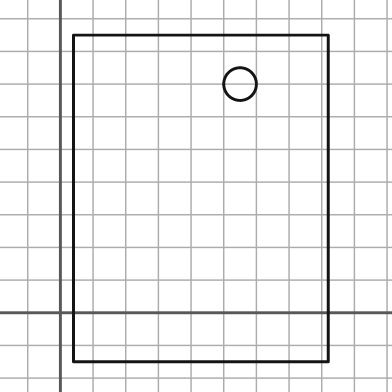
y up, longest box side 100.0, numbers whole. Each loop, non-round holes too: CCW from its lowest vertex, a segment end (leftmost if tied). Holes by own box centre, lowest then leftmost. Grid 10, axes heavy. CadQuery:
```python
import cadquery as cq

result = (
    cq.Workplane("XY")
    .moveTo(4.0, -15.0)
    .lineTo(82.0, -15.0)
    .lineTo(82.0, 85.0)
    .lineTo(4.0, 85.0)
    .close()
    .moveTo(55.0, 70.0)
    .circle(5.0)
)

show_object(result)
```